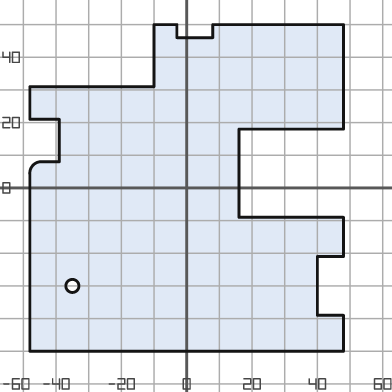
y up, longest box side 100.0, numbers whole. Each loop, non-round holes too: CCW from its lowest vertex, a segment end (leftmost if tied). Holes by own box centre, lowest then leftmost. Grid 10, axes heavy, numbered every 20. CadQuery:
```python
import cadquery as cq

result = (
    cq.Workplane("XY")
    .moveTo(-48.0, -50.0)
    .lineTo(48.0, -50.0)
    .lineTo(48.0, -39.0)
    .lineTo(40.0, -39.0)
    .lineTo(40.0, -21.0)
    .lineTo(48.0, -21.0)
    .lineTo(48.0, -9.0)
    .lineTo(16.0, -9.0)
    .lineTo(16.0, 18.0)
    .lineTo(48.0, 18.0)
    .lineTo(48.0, 50.0)
    .lineTo(8.0, 50.0)
    .lineTo(8.0, 46.0)
    .lineTo(-3.0, 46.0)
    .lineTo(-3.0, 50.0)
    .lineTo(-10.0, 50.0)
    .lineTo(-10.0, 31.0)
    .lineTo(-48.0, 31.0)
    .lineTo(-48.0, 21.0)
    .lineTo(-39.0, 21.0)
    .lineTo(-39.0, 8.0)
    .lineTo(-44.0, 8.0)
    .threePointArc((-47.0, 7.0), (-48.0, 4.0))
    .close()
    .moveTo(-35.0, -30.0)
    .circle(2.0)
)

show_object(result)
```